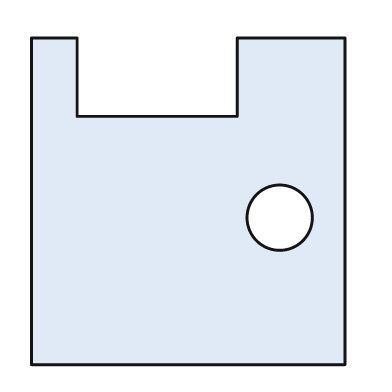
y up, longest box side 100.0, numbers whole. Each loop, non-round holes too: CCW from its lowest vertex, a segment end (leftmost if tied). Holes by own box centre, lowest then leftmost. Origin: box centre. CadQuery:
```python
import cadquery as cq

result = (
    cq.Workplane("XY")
    .moveTo(-48.0, -50.0)
    .lineTo(48.0, -50.0)
    .lineTo(48.0, 50.0)
    .lineTo(15.0, 50.0)
    .lineTo(15.0, 26.0)
    .lineTo(-34.0, 26.0)
    .lineTo(-34.0, 50.0)
    .lineTo(-48.0, 50.0)
    .close()
    .moveTo(28.0, -5.0)
    .circle(10.0)
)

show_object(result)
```